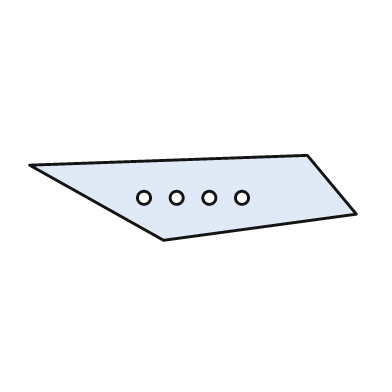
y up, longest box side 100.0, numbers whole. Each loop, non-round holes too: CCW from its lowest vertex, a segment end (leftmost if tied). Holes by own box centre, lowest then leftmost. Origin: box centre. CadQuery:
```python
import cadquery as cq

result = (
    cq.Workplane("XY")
    .moveTo(-9.0, -13.0)
    .lineTo(50.0, -5.0)
    .lineTo(35.0, 13.0)
    .lineTo(-50.0, 10.0)
    .close()
    .moveTo(-15.0, 0.0)
    .circle(2.0)
    .moveTo(-5.0, 0.0)
    .circle(2.0)
    .moveTo(5.0, 0.0)
    .circle(2.0)
    .moveTo(15.0, 0.0)
    .circle(2.0)
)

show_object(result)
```